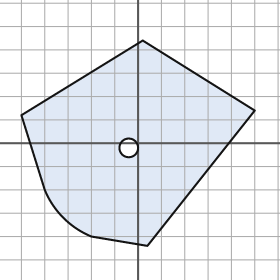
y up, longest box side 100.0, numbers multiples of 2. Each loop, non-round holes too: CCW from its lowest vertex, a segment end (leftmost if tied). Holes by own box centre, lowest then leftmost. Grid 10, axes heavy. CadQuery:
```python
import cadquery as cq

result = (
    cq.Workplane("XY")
    .moveTo(4.0, -44.0)
    .lineTo(50.0, 14.0)
    .lineTo(2.0, 44.0)
    .lineTo(-50.0, 12.0)
    .lineTo(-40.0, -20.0)
    .threePointArc((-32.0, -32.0), (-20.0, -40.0))
    .close()
    .moveTo(-4.0, -2.0)
    .circle(4.0)
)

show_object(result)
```